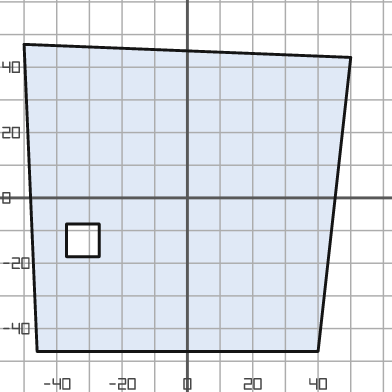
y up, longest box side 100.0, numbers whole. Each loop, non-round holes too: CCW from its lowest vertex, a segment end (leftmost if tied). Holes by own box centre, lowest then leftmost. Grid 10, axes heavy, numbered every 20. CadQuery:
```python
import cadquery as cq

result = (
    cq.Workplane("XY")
    .moveTo(-46.0, -47.0)
    .lineTo(40.0, -47.0)
    .lineTo(50.0, 43.0)
    .lineTo(-50.0, 47.0)
    .close()
    .moveTo(-37.0, -18.0)
    .lineTo(-27.0, -18.0)
    .lineTo(-27.0, -8.0)
    .lineTo(-37.0, -8.0)
    .close()
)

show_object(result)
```